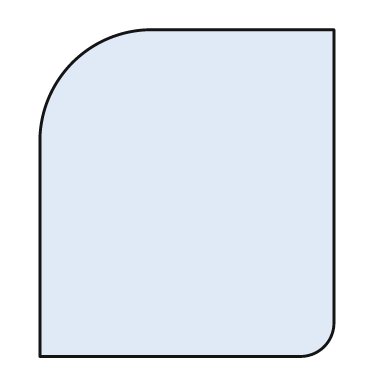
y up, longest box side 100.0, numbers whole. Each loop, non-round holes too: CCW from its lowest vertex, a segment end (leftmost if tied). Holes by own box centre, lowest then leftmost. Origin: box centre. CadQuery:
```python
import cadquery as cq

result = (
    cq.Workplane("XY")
    .moveTo(-45.0, -50.0)
    .lineTo(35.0, -50.0)
    .threePointArc((42.0, -47.0), (45.0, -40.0))
    .lineTo(45.0, 50.0)
    .lineTo(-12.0, 50.0)
    .threePointArc((-35.0, 40.0), (-45.0, 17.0))
    .close()
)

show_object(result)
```